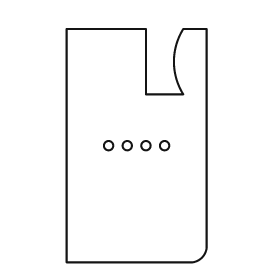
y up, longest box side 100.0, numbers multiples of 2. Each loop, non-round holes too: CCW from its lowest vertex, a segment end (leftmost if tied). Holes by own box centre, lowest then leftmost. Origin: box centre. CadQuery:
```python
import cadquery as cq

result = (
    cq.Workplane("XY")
    .moveTo(-30.0, -50.0)
    .lineTo(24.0, -50.0)
    .threePointArc((28.0, -48.0), (30.0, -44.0))
    .lineTo(30.0, 50.0)
    .lineTo(20.0, 50.0)
    .threePointArc((16.0, 36.0), (20.0, 22.0))
    .lineTo(4.0, 22.0)
    .lineTo(4.0, 50.0)
    .lineTo(-30.0, 50.0)
    .close()
    .moveTo(-12.0, 0.0)
    .circle(2.0)
    .moveTo(-4.0, 0.0)
    .circle(2.0)
    .moveTo(4.0, 0.0)
    .circle(2.0)
    .moveTo(12.0, 0.0)
    .circle(2.0)
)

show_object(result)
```